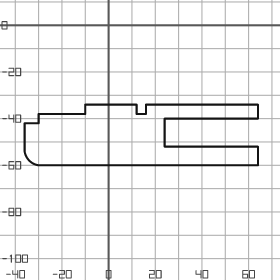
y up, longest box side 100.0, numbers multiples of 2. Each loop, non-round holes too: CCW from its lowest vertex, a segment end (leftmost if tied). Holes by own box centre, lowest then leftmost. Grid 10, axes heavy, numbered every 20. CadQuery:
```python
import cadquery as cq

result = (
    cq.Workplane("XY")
    .moveTo(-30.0, -60.0)
    .lineTo(64.0, -60.0)
    .lineTo(64.0, -52.0)
    .lineTo(24.0, -52.0)
    .lineTo(24.0, -40.0)
    .lineTo(64.0, -40.0)
    .lineTo(64.0, -34.0)
    .lineTo(16.0, -34.0)
    .lineTo(16.0, -38.0)
    .lineTo(12.0, -38.0)
    .lineTo(12.0, -34.0)
    .lineTo(-10.0, -34.0)
    .lineTo(-10.0, -38.0)
    .lineTo(-30.0, -38.0)
    .lineTo(-30.0, -42.0)
    .lineTo(-36.0, -42.0)
    .lineTo(-36.0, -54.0)
    .threePointArc((-34.0, -58.0), (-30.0, -60.0))
    .close()
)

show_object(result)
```